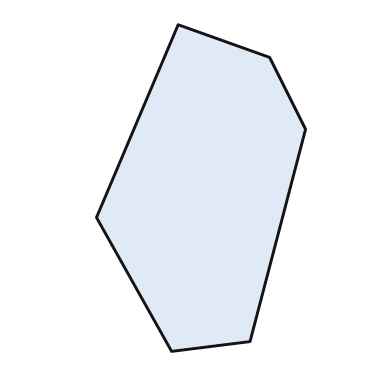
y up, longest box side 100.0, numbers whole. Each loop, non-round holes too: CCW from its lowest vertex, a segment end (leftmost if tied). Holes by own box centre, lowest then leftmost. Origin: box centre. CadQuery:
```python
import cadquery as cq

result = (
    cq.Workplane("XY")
    .moveTo(-9.0, -50.0)
    .lineTo(15.0, -47.0)
    .lineTo(32.0, 18.0)
    .lineTo(21.0, 40.0)
    .lineTo(-7.0, 50.0)
    .lineTo(-32.0, -9.0)
    .close()
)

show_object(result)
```